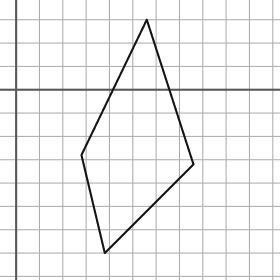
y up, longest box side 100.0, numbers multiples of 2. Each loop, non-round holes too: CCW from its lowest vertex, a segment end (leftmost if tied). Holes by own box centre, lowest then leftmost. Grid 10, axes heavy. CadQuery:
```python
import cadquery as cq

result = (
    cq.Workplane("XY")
    .moveTo(38.0, -70.0)
    .lineTo(76.0, -32.0)
    .lineTo(56.0, 30.0)
    .lineTo(28.0, -28.0)
    .close()
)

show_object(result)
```